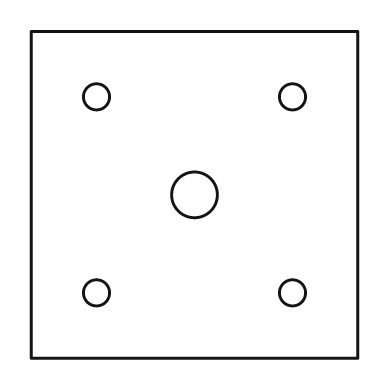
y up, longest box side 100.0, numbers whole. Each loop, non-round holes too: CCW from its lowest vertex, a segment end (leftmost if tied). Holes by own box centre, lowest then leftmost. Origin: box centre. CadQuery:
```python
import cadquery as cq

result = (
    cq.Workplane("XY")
    .moveTo(-50.0, -50.0)
    .lineTo(50.0, -50.0)
    .lineTo(50.0, 50.0)
    .lineTo(-50.0, 50.0)
    .close()
    .moveTo(-30.0, -30.0)
    .circle(4.0)
    .moveTo(30.0, -30.0)
    .circle(4.0)
    .moveTo(0.0, 0.0)
    .circle(7.0)
    .moveTo(-30.0, 30.0)
    .circle(4.0)
    .moveTo(30.0, 30.0)
    .circle(4.0)
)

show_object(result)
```